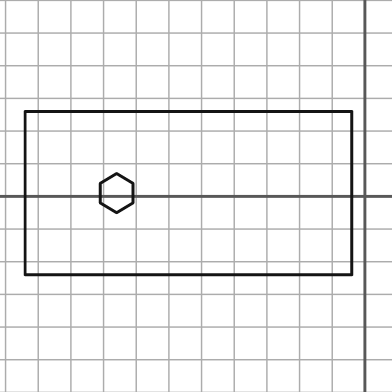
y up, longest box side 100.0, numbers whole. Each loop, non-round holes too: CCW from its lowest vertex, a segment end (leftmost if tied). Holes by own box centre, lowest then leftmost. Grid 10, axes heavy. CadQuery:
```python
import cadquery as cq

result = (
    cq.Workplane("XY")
    .moveTo(-104.0, -24.0)
    .lineTo(-4.0, -24.0)
    .lineTo(-4.0, 26.0)
    .lineTo(-104.0, 26.0)
    .close()
    .moveTo(-76.0, -5.0)
    .lineTo(-71.0, -2.0)
    .lineTo(-71.0, 4.0)
    .lineTo(-76.0, 7.0)
    .lineTo(-81.0, 4.0)
    .lineTo(-81.0, -2.0)
    .close()
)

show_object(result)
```